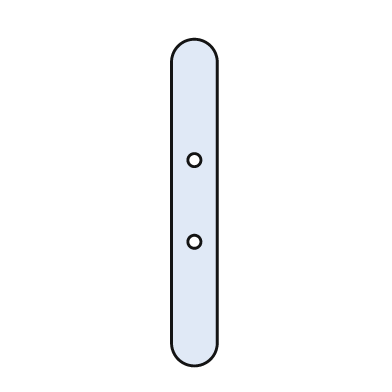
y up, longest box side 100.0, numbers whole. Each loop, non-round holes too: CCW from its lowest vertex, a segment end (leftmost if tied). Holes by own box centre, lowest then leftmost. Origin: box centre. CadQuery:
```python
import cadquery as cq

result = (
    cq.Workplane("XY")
    .moveTo(-7.0, -43.0)
    .threePointArc((0.0, -50.0), (7.0, -43.0))
    .lineTo(7.0, 43.0)
    .threePointArc((0.0, 50.0), (-7.0, 43.0))
    .close()
    .moveTo(0.0, -12.0)
    .circle(2.0)
    .moveTo(0.0, 13.0)
    .circle(2.0)
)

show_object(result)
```